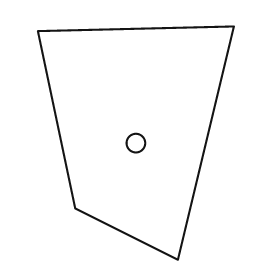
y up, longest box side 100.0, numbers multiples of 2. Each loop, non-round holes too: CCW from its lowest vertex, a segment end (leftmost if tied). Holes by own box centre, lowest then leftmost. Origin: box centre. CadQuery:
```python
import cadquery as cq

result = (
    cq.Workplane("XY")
    .moveTo(18.0, -50.0)
    .lineTo(42.0, 50.0)
    .lineTo(-42.0, 48.0)
    .lineTo(-26.0, -28.0)
    .close()
    .moveTo(0.0, 0.0)
    .circle(4.0)
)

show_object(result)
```